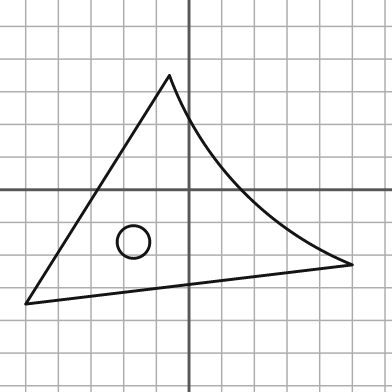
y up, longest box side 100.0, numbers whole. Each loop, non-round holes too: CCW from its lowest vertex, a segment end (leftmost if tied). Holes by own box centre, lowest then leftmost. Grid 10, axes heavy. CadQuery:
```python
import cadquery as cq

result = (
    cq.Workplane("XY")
    .moveTo(-50.0, -35.0)
    .lineTo(50.0, -23.0)
    .threePointArc((16.0, 0.0), (-6.0, 35.0))
    .close()
    .moveTo(-17.0, -16.0)
    .circle(5.0)
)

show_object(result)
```